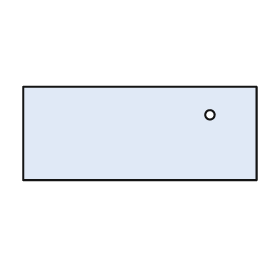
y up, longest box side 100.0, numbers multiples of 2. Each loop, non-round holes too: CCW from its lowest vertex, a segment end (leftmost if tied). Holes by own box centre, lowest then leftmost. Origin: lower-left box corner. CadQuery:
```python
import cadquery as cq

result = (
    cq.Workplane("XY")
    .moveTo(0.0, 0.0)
    .lineTo(100.0, 0.0)
    .lineTo(100.0, 40.0)
    .lineTo(0.0, 40.0)
    .close()
    .moveTo(80.0, 28.0)
    .circle(2.0)
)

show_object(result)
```